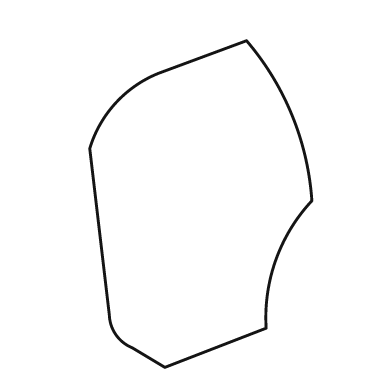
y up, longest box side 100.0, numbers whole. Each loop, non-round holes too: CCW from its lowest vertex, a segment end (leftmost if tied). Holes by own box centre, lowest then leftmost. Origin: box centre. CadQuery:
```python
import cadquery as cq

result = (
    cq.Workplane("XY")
    .moveTo(-11.0, -50.0)
    .lineTo(20.0, -38.0)
    .threePointArc((23.0, -17.0), (34.0, 1.0))
    .threePointArc((28.0, 27.0), (14.0, 50.0))
    .lineTo(-13.0, 40.0)
    .threePointArc((-26.0, 31.0), (-34.0, 17.0))
    .lineTo(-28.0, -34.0)
    .threePointArc((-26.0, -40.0), (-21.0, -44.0))
    .close()
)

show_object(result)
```